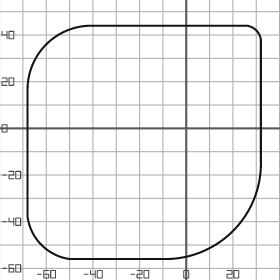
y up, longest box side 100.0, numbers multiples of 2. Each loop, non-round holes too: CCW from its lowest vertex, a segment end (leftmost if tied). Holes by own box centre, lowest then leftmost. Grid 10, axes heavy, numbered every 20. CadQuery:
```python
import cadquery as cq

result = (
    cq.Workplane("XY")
    .moveTo(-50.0, -56.0)
    .lineTo(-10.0, -56.0)
    .threePointArc((20.0, -44.0), (32.0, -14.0))
    .lineTo(32.0, 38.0)
    .threePointArc((30.0, 42.0), (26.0, 44.0))
    .lineTo(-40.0, 44.0)
    .threePointArc((-60.0, 36.0), (-68.0, 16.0))
    .lineTo(-68.0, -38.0)
    .threePointArc((-62.0, -50.0), (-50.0, -56.0))
    .close()
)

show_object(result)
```